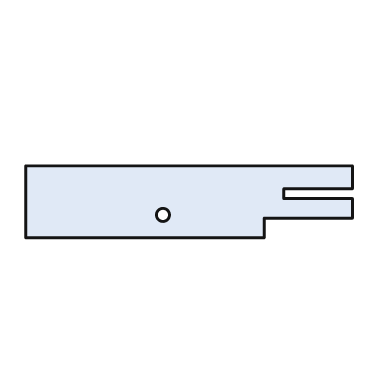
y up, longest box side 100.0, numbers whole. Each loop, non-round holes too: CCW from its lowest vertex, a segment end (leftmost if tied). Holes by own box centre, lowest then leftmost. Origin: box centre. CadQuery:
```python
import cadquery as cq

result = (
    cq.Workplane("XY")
    .moveTo(-50.0, -11.0)
    .lineTo(23.0, -11.0)
    .lineTo(23.0, -5.0)
    .lineTo(50.0, -5.0)
    .lineTo(50.0, 1.0)
    .lineTo(29.0, 1.0)
    .lineTo(29.0, 4.0)
    .lineTo(50.0, 4.0)
    .lineTo(50.0, 11.0)
    .lineTo(-50.0, 11.0)
    .close()
    .moveTo(-8.0, -4.0)
    .circle(2.0)
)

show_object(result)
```